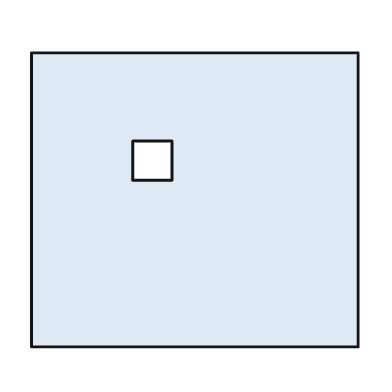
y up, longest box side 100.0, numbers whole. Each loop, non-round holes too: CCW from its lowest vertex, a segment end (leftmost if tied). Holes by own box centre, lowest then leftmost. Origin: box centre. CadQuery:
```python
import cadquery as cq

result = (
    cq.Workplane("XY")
    .moveTo(-50.0, -45.0)
    .lineTo(50.0, -45.0)
    .lineTo(50.0, 45.0)
    .lineTo(-50.0, 45.0)
    .close()
    .moveTo(-19.0, 6.0)
    .lineTo(-7.0, 6.0)
    .lineTo(-7.0, 18.0)
    .lineTo(-19.0, 18.0)
    .close()
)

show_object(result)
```